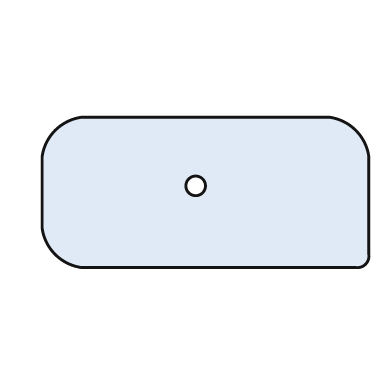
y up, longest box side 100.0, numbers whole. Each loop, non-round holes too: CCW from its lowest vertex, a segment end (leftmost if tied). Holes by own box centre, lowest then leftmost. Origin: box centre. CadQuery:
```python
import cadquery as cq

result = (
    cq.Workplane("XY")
    .moveTo(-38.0, -23.0)
    .lineTo(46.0, -23.0)
    .threePointArc((49.0, -22.0), (50.0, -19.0))
    .lineTo(50.0, 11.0)
    .threePointArc((46.0, 19.0), (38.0, 23.0))
    .lineTo(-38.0, 23.0)
    .threePointArc((-46.0, 19.0), (-50.0, 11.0))
    .lineTo(-50.0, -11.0)
    .threePointArc((-46.0, -19.0), (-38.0, -23.0))
    .close()
    .moveTo(-3.0, 2.0)
    .circle(3.0)
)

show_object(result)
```